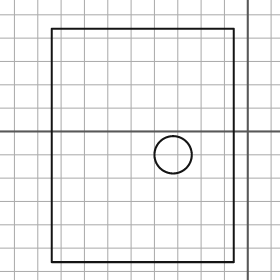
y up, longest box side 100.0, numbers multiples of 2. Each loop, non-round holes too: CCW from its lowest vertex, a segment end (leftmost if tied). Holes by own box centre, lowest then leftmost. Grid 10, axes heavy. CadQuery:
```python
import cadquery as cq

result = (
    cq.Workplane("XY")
    .moveTo(-84.0, -56.0)
    .lineTo(-6.0, -56.0)
    .lineTo(-6.0, 44.0)
    .lineTo(-84.0, 44.0)
    .close()
    .moveTo(-32.0, -10.0)
    .circle(8.0)
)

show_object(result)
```